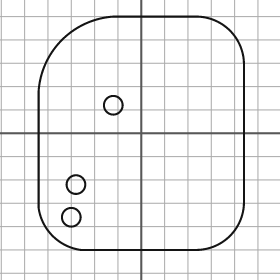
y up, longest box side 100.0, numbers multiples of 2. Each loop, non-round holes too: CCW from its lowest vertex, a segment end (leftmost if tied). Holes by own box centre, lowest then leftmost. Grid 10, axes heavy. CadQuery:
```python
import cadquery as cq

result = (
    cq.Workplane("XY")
    .moveTo(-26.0, -50.0)
    .lineTo(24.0, -50.0)
    .threePointArc((38.0, -44.0), (44.0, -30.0))
    .lineTo(44.0, 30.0)
    .threePointArc((38.0, 44.0), (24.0, 50.0))
    .lineTo(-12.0, 50.0)
    .threePointArc((-34.0, 40.0), (-44.0, 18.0))
    .lineTo(-44.0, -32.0)
    .threePointArc((-38.0, -44.0), (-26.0, -50.0))
    .close()
    .moveTo(-30.0, -36.0)
    .circle(4.0)
    .moveTo(-28.0, -22.0)
    .circle(4.0)
    .moveTo(-12.0, 12.0)
    .circle(4.0)
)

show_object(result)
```